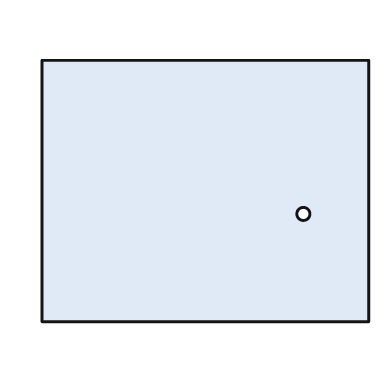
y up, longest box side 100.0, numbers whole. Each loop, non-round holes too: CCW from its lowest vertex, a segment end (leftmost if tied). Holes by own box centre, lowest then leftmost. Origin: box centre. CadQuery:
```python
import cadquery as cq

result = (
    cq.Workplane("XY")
    .moveTo(-50.0, -40.0)
    .lineTo(50.0, -40.0)
    .lineTo(50.0, 40.0)
    .lineTo(-50.0, 40.0)
    .close()
    .moveTo(30.0, -7.0)
    .circle(2.0)
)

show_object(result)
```